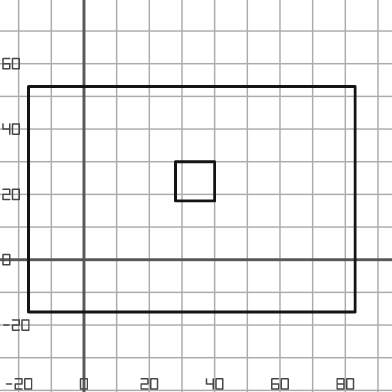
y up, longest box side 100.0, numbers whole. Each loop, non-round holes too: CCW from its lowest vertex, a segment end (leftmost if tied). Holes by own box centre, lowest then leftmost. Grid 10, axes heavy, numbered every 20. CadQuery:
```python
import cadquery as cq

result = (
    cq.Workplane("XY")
    .moveTo(-17.0, -16.0)
    .lineTo(83.0, -16.0)
    .lineTo(83.0, 53.0)
    .lineTo(-17.0, 53.0)
    .close()
    .moveTo(28.0, 18.0)
    .lineTo(40.0, 18.0)
    .lineTo(40.0, 30.0)
    .lineTo(28.0, 30.0)
    .close()
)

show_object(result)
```